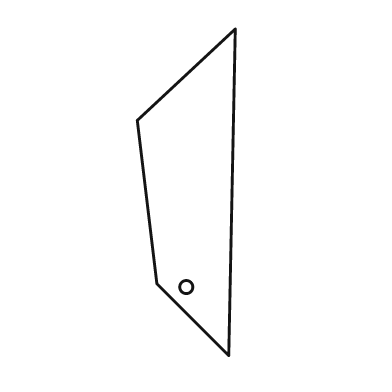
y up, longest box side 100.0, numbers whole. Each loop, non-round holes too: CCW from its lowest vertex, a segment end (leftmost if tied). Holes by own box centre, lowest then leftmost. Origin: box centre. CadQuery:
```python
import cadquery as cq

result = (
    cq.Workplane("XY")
    .moveTo(13.0, -50.0)
    .lineTo(15.0, 50.0)
    .lineTo(-15.0, 22.0)
    .lineTo(-9.0, -28.0)
    .close()
    .moveTo(0.0, -29.0)
    .circle(2.0)
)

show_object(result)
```